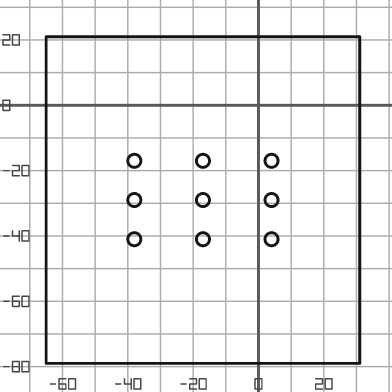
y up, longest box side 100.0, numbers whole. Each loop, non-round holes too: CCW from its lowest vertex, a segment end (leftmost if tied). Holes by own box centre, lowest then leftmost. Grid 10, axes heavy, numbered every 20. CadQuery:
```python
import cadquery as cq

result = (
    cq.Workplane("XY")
    .moveTo(-65.0, -79.0)
    .lineTo(31.0, -79.0)
    .lineTo(31.0, 21.0)
    .lineTo(-65.0, 21.0)
    .close()
    .moveTo(-38.0, -41.0)
    .circle(2.0)
    .moveTo(-17.0, -41.0)
    .circle(2.0)
    .moveTo(4.0, -41.0)
    .circle(2.0)
    .moveTo(-38.0, -29.0)
    .circle(2.0)
    .moveTo(-17.0, -29.0)
    .circle(2.0)
    .moveTo(4.0, -29.0)
    .circle(2.0)
    .moveTo(-38.0, -17.0)
    .circle(2.0)
    .moveTo(-17.0, -17.0)
    .circle(2.0)
    .moveTo(4.0, -17.0)
    .circle(2.0)
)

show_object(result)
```